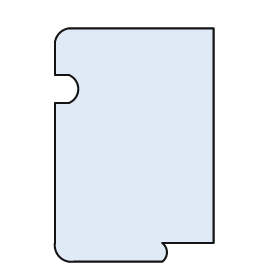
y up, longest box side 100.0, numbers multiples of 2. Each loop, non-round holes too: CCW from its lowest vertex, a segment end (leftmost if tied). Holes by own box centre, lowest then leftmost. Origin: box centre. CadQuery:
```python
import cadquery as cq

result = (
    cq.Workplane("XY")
    .moveTo(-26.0, -50.0)
    .lineTo(12.0, -50.0)
    .threePointArc((14.0, -46.0), (12.0, -42.0))
    .lineTo(34.0, -42.0)
    .lineTo(34.0, 50.0)
    .lineTo(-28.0, 50.0)
    .threePointArc((-32.0, 48.0), (-34.0, 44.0))
    .lineTo(-34.0, 30.0)
    .lineTo(-28.0, 30.0)
    .threePointArc((-24.0, 24.0), (-28.0, 18.0))
    .lineTo(-34.0, 18.0)
    .lineTo(-34.0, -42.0)
    .threePointArc((-32.0, -48.0), (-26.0, -50.0))
    .close()
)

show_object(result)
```